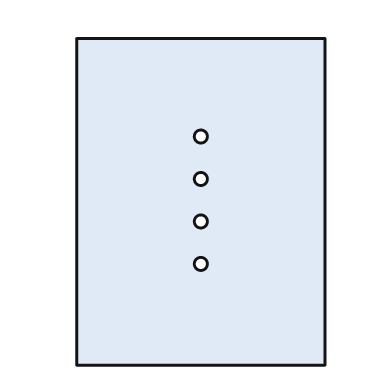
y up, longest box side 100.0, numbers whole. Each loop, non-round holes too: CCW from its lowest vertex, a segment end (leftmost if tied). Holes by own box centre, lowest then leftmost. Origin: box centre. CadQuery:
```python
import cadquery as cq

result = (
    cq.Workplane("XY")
    .moveTo(-38.0, -50.0)
    .lineTo(38.0, -50.0)
    .lineTo(38.0, 50.0)
    .lineTo(-38.0, 50.0)
    .close()
    .moveTo(0.0, -19.0)
    .circle(2.0)
    .moveTo(0.0, -6.0)
    .circle(2.0)
    .moveTo(0.0, 7.0)
    .circle(2.0)
    .moveTo(0.0, 20.0)
    .circle(2.0)
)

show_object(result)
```